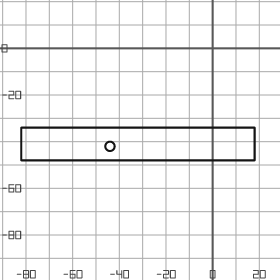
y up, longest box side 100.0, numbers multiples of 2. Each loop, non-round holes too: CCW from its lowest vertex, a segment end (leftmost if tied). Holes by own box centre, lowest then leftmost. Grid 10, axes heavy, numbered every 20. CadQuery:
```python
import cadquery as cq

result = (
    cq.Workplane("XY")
    .moveTo(-82.0, -48.0)
    .lineTo(18.0, -48.0)
    .lineTo(18.0, -34.0)
    .lineTo(-82.0, -34.0)
    .close()
    .moveTo(-44.0, -42.0)
    .circle(2.0)
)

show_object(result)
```